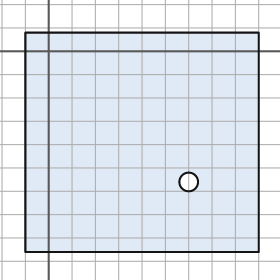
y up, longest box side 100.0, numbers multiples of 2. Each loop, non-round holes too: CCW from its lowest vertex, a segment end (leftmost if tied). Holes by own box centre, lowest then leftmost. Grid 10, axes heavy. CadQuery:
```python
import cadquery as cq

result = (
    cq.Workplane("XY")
    .moveTo(-10.0, -86.0)
    .lineTo(90.0, -86.0)
    .lineTo(90.0, 8.0)
    .lineTo(-10.0, 8.0)
    .close()
    .moveTo(60.0, -56.0)
    .circle(4.0)
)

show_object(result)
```